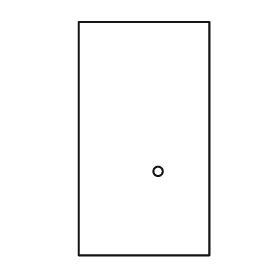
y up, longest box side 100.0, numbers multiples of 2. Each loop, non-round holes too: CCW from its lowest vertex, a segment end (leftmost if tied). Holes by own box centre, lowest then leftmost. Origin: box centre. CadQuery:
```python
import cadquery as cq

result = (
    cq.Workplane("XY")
    .moveTo(-28.0, -50.0)
    .lineTo(28.0, -50.0)
    .lineTo(28.0, 50.0)
    .lineTo(-28.0, 50.0)
    .close()
    .moveTo(6.0, -14.0)
    .circle(2.0)
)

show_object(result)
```